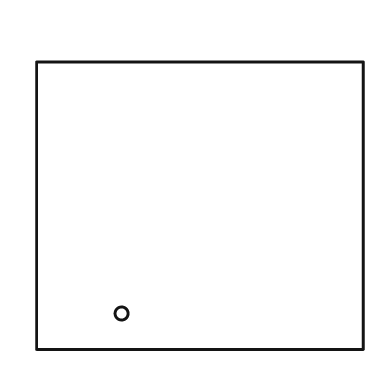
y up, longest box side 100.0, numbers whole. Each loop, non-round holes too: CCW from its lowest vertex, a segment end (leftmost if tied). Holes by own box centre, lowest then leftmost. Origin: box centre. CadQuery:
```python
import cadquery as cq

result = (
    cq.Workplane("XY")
    .moveTo(-50.0, -44.0)
    .lineTo(50.0, -44.0)
    .lineTo(50.0, 44.0)
    .lineTo(-50.0, 44.0)
    .close()
    .moveTo(-24.0, -33.0)
    .circle(2.0)
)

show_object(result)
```